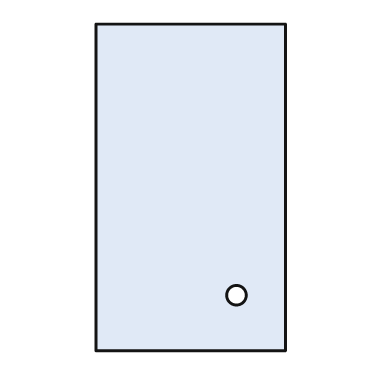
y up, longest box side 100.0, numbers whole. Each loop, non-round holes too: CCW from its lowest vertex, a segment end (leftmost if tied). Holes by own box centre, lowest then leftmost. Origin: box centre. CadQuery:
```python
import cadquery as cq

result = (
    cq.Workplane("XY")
    .moveTo(-29.0, -50.0)
    .lineTo(29.0, -50.0)
    .lineTo(29.0, 50.0)
    .lineTo(-29.0, 50.0)
    .close()
    .moveTo(14.0, -33.0)
    .circle(3.0)
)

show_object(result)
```